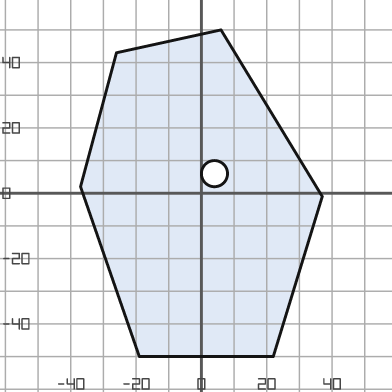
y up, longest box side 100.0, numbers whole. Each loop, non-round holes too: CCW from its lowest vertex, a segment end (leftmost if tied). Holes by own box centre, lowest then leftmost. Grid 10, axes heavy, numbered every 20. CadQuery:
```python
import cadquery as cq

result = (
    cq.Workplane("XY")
    .moveTo(-19.0, -50.0)
    .lineTo(22.0, -50.0)
    .lineTo(37.0, -1.0)
    .lineTo(6.0, 50.0)
    .lineTo(-26.0, 43.0)
    .lineTo(-37.0, 2.0)
    .close()
    .moveTo(4.0, 6.0)
    .circle(4.0)
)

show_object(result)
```